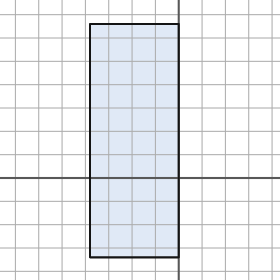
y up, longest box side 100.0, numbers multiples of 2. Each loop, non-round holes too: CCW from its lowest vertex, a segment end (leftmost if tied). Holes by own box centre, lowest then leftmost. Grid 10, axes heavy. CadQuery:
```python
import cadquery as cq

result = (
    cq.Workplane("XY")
    .moveTo(-38.0, -34.0)
    .lineTo(0.0, -34.0)
    .lineTo(0.0, 66.0)
    .lineTo(-38.0, 66.0)
    .close()
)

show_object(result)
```